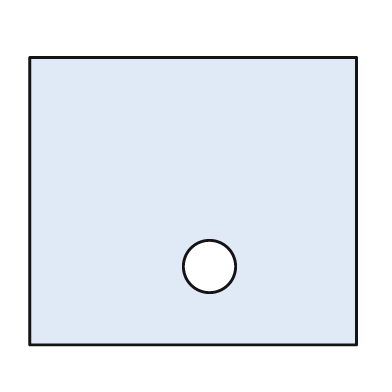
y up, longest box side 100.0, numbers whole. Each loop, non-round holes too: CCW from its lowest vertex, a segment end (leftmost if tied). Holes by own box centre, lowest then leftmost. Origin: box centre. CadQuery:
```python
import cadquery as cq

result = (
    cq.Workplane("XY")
    .moveTo(-50.0, -44.0)
    .lineTo(50.0, -44.0)
    .lineTo(50.0, 44.0)
    .lineTo(-50.0, 44.0)
    .close()
    .moveTo(5.0, -20.0)
    .circle(8.0)
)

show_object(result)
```